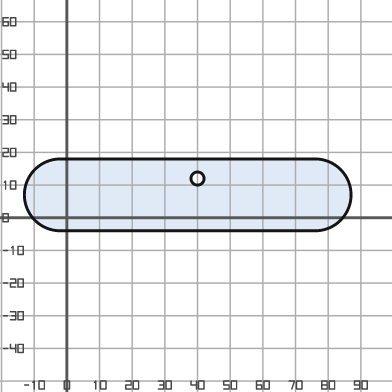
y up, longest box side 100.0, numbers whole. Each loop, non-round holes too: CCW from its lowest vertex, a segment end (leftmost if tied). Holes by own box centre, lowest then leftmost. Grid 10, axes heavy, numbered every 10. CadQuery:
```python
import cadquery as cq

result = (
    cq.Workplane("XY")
    .moveTo(-2.0, -4.0)
    .lineTo(76.0, -4.0)
    .threePointArc((87.0, 7.0), (76.0, 18.0))
    .lineTo(-2.0, 18.0)
    .threePointArc((-13.0, 7.0), (-2.0, -4.0))
    .close()
    .moveTo(40.0, 12.0)
    .circle(2.0)
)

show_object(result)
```